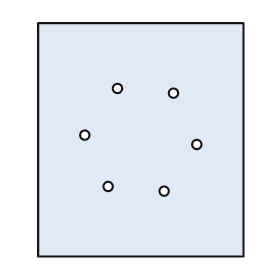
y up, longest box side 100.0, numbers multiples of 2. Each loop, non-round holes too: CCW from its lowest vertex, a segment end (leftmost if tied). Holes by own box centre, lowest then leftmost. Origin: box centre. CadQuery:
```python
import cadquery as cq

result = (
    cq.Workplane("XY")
    .moveTo(-44.0, -50.0)
    .lineTo(44.0, -50.0)
    .lineTo(44.0, 50.0)
    .lineTo(-44.0, 50.0)
    .close()
    .moveTo(10.0, -22.0)
    .circle(2.0)
    .moveTo(-14.0, -20.0)
    .circle(2.0)
    .moveTo(24.0, -2.0)
    .circle(2.0)
    .moveTo(-24.0, 2.0)
    .circle(2.0)
    .moveTo(14.0, 20.0)
    .circle(2.0)
    .moveTo(-10.0, 22.0)
    .circle(2.0)
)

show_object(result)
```